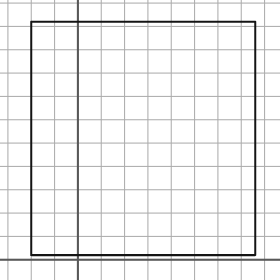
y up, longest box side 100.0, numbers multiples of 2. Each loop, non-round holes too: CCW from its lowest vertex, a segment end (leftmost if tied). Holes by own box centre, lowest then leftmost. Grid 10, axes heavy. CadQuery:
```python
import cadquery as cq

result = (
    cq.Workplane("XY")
    .moveTo(-20.0, 2.0)
    .lineTo(76.0, 2.0)
    .lineTo(76.0, 102.0)
    .lineTo(-20.0, 102.0)
    .close()
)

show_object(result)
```